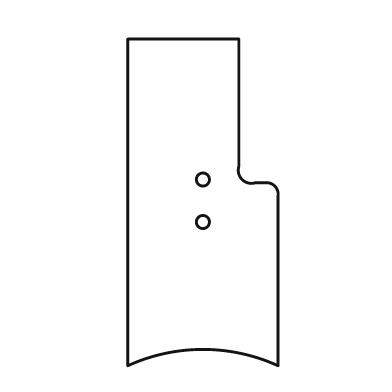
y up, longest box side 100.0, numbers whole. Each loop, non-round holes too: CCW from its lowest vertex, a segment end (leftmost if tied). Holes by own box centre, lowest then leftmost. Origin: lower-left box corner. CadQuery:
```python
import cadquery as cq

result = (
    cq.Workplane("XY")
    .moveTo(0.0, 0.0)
    .threePointArc((23.0, 5.0), (46.0, 0.0))
    .lineTo(46.0, 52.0)
    .threePointArc((45.0, 55.0), (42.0, 56.0))
    .lineTo(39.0, 56.0)
    .threePointArc((35.0, 57.0), (34.0, 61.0))
    .lineTo(34.0, 100.0)
    .lineTo(0.0, 100.0)
    .close()
    .moveTo(23.0, 44.0)
    .circle(2.0)
    .moveTo(23.0, 57.0)
    .circle(2.0)
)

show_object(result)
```